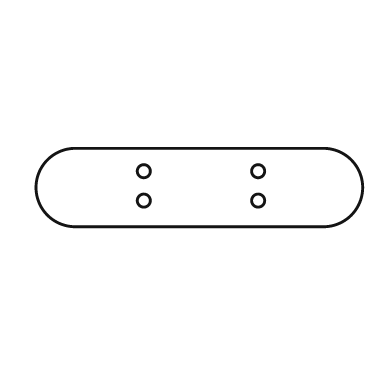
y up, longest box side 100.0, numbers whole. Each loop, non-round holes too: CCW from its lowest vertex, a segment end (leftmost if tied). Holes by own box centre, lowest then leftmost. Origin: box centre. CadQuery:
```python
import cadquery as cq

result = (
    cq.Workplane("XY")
    .moveTo(-38.0, -12.0)
    .lineTo(38.0, -12.0)
    .threePointArc((50.0, 0.0), (38.0, 12.0))
    .lineTo(-38.0, 12.0)
    .threePointArc((-50.0, 0.0), (-38.0, -12.0))
    .close()
    .moveTo(-17.0, -4.0)
    .circle(2.0)
    .moveTo(18.0, -4.0)
    .circle(2.0)
    .moveTo(-17.0, 5.0)
    .circle(2.0)
    .moveTo(18.0, 5.0)
    .circle(2.0)
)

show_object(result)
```